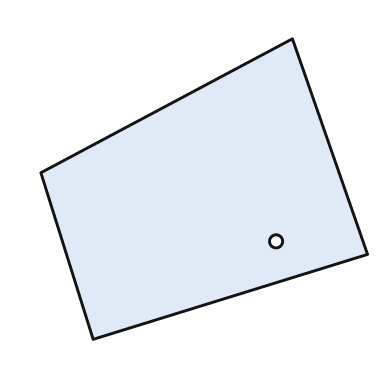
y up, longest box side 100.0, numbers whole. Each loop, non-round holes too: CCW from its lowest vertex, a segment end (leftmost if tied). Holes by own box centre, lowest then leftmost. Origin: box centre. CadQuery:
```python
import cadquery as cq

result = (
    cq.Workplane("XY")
    .moveTo(-34.0, -46.0)
    .lineTo(50.0, -20.0)
    .lineTo(27.0, 46.0)
    .lineTo(-50.0, 5.0)
    .close()
    .moveTo(22.0, -16.0)
    .circle(2.0)
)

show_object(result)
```